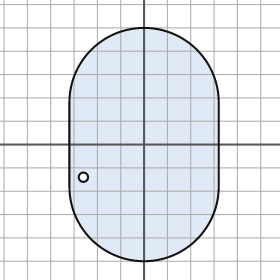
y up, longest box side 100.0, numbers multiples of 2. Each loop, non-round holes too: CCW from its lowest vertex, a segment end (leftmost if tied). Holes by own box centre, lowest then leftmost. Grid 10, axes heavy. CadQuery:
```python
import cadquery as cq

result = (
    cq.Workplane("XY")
    .moveTo(-32.0, -18.0)
    .threePointArc((0.0, -50.0), (32.0, -18.0))
    .lineTo(32.0, 18.0)
    .threePointArc((0.0, 50.0), (-32.0, 18.0))
    .close()
    .moveTo(-26.0, -14.0)
    .circle(2.0)
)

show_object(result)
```